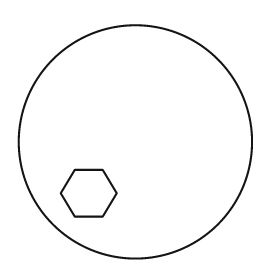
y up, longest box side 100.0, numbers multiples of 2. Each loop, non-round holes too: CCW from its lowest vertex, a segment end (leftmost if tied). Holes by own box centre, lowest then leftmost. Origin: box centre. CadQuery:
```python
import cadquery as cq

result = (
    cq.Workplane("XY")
    .moveTo(0.0, 0.0)
    .circle(50.0)
    .moveTo(-26.0, -32.0)
    .lineTo(-14.0, -32.0)
    .lineTo(-8.0, -22.0)
    .lineTo(-14.0, -12.0)
    .lineTo(-26.0, -12.0)
    .lineTo(-32.0, -22.0)
    .close()
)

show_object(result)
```